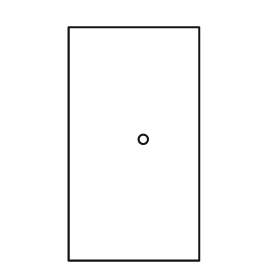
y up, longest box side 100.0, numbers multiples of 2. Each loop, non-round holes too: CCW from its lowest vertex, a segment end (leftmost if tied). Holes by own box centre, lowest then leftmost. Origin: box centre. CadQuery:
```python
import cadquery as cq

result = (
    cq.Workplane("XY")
    .moveTo(-28.0, -50.0)
    .lineTo(28.0, -50.0)
    .lineTo(28.0, 50.0)
    .lineTo(-28.0, 50.0)
    .close()
    .moveTo(4.0, 2.0)
    .circle(2.0)
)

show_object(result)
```